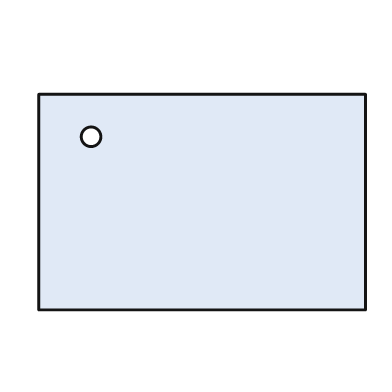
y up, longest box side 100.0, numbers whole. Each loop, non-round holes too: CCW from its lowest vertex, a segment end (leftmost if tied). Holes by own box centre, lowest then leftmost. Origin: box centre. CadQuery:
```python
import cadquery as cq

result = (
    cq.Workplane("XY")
    .moveTo(-50.0, -33.0)
    .lineTo(50.0, -33.0)
    .lineTo(50.0, 33.0)
    .lineTo(-50.0, 33.0)
    .close()
    .moveTo(-34.0, 20.0)
    .circle(3.0)
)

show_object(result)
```